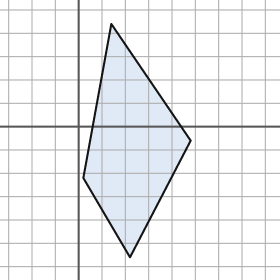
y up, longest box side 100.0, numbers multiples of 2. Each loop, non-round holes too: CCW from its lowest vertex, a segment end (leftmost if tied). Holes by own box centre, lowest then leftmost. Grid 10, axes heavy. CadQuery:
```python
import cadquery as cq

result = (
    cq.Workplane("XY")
    .moveTo(22.0, -56.0)
    .lineTo(48.0, -6.0)
    .lineTo(14.0, 44.0)
    .lineTo(2.0, -22.0)
    .close()
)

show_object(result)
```